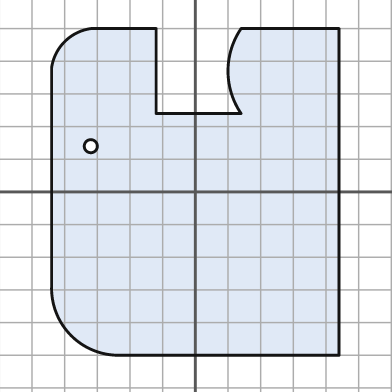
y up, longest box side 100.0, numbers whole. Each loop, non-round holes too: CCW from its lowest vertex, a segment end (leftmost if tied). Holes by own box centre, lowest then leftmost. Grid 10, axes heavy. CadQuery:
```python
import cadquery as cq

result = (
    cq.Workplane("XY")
    .moveTo(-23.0, -50.0)
    .lineTo(44.0, -50.0)
    .lineTo(44.0, 50.0)
    .lineTo(14.0, 50.0)
    .threePointArc((10.0, 37.0), (14.0, 24.0))
    .lineTo(-12.0, 24.0)
    .lineTo(-12.0, 50.0)
    .lineTo(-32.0, 50.0)
    .threePointArc((-40.0, 46.0), (-44.0, 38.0))
    .lineTo(-44.0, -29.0)
    .threePointArc((-38.0, -44.0), (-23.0, -50.0))
    .close()
    .moveTo(-32.0, 14.0)
    .circle(2.0)
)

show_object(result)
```